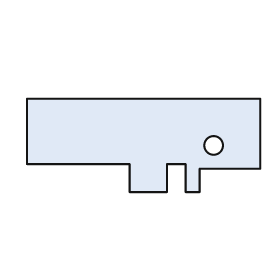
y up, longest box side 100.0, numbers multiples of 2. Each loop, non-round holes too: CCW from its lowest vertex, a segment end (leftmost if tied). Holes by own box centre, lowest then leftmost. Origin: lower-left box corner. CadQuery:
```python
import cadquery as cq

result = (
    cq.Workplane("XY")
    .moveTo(44.0, 0.0)
    .lineTo(60.0, 0.0)
    .lineTo(60.0, 12.0)
    .lineTo(68.0, 12.0)
    .lineTo(68.0, 0.0)
    .lineTo(74.0, 0.0)
    .lineTo(74.0, 10.0)
    .lineTo(100.0, 10.0)
    .lineTo(100.0, 40.0)
    .lineTo(0.0, 40.0)
    .lineTo(0.0, 12.0)
    .lineTo(44.0, 12.0)
    .close()
    .moveTo(80.0, 20.0)
    .circle(4.0)
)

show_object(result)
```